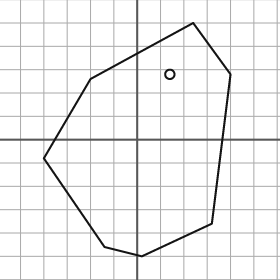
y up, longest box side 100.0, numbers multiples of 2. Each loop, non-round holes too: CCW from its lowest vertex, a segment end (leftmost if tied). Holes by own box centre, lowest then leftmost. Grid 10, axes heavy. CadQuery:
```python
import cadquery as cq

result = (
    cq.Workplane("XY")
    .moveTo(2.0, -50.0)
    .lineTo(32.0, -36.0)
    .lineTo(40.0, 28.0)
    .lineTo(24.0, 50.0)
    .lineTo(-20.0, 26.0)
    .lineTo(-40.0, -8.0)
    .lineTo(-14.0, -46.0)
    .close()
    .moveTo(14.0, 28.0)
    .circle(2.0)
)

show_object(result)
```